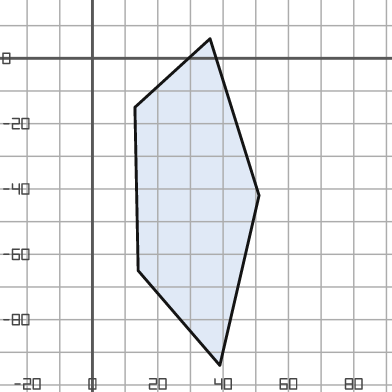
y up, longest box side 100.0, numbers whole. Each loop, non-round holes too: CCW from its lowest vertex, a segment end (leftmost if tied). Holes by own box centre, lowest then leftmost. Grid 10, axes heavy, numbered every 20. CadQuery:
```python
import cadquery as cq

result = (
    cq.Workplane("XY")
    .moveTo(39.0, -94.0)
    .lineTo(51.0, -42.0)
    .lineTo(36.0, 6.0)
    .lineTo(13.0, -15.0)
    .lineTo(14.0, -65.0)
    .close()
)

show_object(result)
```